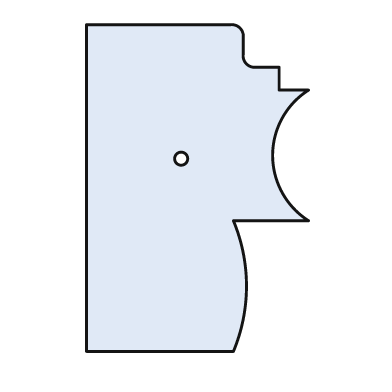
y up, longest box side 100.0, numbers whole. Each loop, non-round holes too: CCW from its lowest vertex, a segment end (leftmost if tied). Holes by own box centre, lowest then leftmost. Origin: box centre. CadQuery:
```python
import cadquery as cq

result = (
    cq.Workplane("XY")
    .moveTo(-34.0, -50.0)
    .lineTo(11.0, -50.0)
    .threePointArc((15.0, -30.0), (11.0, -10.0))
    .lineTo(34.0, -10.0)
    .threePointArc((23.0, 10.0), (34.0, 30.0))
    .lineTo(25.0, 30.0)
    .lineTo(25.0, 37.0)
    .lineTo(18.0, 37.0)
    .threePointArc((15.0, 38.0), (14.0, 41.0))
    .lineTo(14.0, 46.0)
    .threePointArc((13.0, 49.0), (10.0, 50.0))
    .lineTo(-34.0, 50.0)
    .close()
    .moveTo(-5.0, 9.0)
    .circle(2.0)
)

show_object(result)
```